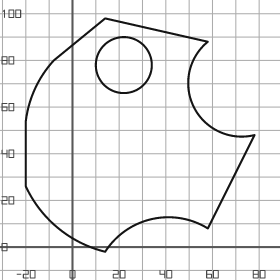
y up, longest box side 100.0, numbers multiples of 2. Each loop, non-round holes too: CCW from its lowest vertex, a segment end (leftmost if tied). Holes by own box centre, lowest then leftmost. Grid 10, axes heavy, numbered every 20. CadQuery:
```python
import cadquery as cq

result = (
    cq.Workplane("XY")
    .moveTo(14.0, -2.0)
    .threePointArc((34.0, 12.0), (58.0, 8.0))
    .lineTo(78.0, 48.0)
    .threePointArc((52.0, 60.0), (58.0, 88.0))
    .lineTo(14.0, 98.0)
    .lineTo(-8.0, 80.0)
    .threePointArc((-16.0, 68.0), (-20.0, 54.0))
    .lineTo(-20.0, 26.0)
    .threePointArc((-6.0, 8.0), (14.0, -2.0))
    .close()
    .moveTo(22.0, 78.0)
    .circle(12.0)
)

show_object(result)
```